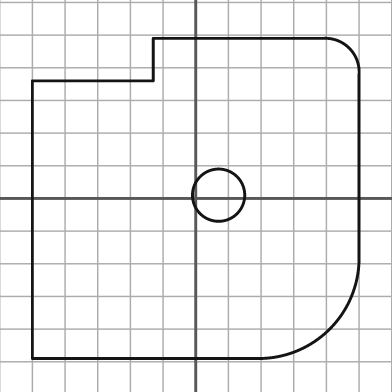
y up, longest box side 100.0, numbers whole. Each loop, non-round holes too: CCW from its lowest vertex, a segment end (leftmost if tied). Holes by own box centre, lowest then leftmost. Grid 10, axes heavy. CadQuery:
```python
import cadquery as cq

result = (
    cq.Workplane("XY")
    .moveTo(-50.0, -49.0)
    .lineTo(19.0, -49.0)
    .threePointArc((41.0, -40.0), (50.0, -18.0))
    .lineTo(50.0, 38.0)
    .threePointArc((47.0, 46.0), (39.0, 49.0))
    .lineTo(-13.0, 49.0)
    .lineTo(-13.0, 36.0)
    .lineTo(-50.0, 36.0)
    .close()
    .moveTo(7.0, 1.0)
    .circle(8.0)
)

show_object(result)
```